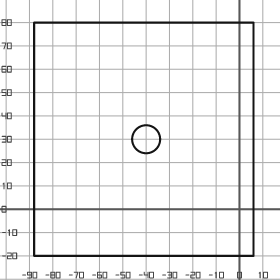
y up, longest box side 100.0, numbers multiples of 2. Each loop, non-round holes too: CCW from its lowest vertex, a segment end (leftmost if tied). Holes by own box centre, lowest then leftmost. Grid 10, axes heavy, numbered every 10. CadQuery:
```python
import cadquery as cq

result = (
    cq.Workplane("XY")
    .moveTo(-88.0, -20.0)
    .lineTo(6.0, -20.0)
    .lineTo(6.0, 80.0)
    .lineTo(-88.0, 80.0)
    .close()
    .moveTo(-40.0, 30.0)
    .circle(6.0)
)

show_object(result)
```